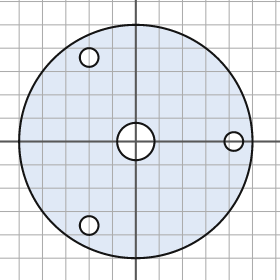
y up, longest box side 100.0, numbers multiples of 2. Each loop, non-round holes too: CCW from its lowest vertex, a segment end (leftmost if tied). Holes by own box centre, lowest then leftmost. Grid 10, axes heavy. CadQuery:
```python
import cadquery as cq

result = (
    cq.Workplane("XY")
    .moveTo(0.0, 0.0)
    .circle(50.0)
    .moveTo(-20.0, -36.0)
    .circle(4.0)
    .moveTo(0.0, 0.0)
    .circle(8.0)
    .moveTo(42.0, 0.0)
    .circle(4.0)
    .moveTo(-20.0, 36.0)
    .circle(4.0)
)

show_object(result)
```